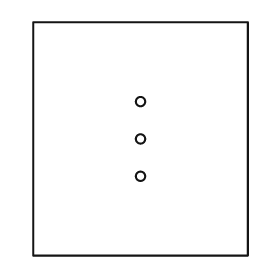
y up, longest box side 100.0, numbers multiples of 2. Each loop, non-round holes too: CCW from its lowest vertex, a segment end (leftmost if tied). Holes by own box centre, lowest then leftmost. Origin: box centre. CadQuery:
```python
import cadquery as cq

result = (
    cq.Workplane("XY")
    .moveTo(-46.0, -50.0)
    .lineTo(46.0, -50.0)
    .lineTo(46.0, 50.0)
    .lineTo(-46.0, 50.0)
    .close()
    .moveTo(0.0, -16.0)
    .circle(2.0)
    .moveTo(0.0, 0.0)
    .circle(2.0)
    .moveTo(0.0, 16.0)
    .circle(2.0)
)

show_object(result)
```